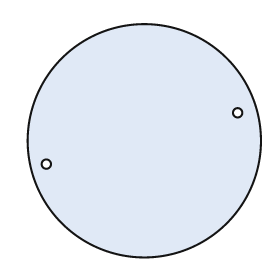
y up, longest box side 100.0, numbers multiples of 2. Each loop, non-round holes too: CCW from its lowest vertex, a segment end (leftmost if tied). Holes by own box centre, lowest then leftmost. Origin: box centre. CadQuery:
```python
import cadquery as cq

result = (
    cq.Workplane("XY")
    .moveTo(0.0, 0.0)
    .circle(50.0)
    .moveTo(-42.0, -10.0)
    .circle(2.0)
    .moveTo(40.0, 12.0)
    .circle(2.0)
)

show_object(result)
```